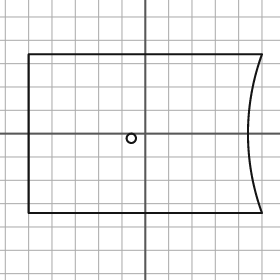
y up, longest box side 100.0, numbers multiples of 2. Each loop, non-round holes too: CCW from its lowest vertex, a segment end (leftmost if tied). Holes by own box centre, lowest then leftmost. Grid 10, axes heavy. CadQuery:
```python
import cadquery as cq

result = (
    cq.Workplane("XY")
    .moveTo(-50.0, -34.0)
    .lineTo(50.0, -34.0)
    .threePointArc((44.0, 0.0), (50.0, 34.0))
    .lineTo(-50.0, 34.0)
    .close()
    .moveTo(-6.0, -2.0)
    .circle(2.0)
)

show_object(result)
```